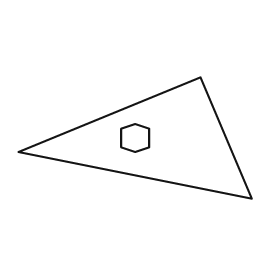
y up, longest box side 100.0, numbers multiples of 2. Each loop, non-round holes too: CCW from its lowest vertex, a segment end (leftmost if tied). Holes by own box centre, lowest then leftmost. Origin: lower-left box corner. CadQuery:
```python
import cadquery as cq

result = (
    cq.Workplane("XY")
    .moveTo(100.0, 0.0)
    .lineTo(78.0, 52.0)
    .lineTo(0.0, 20.0)
    .close()
    .moveTo(50.0, 20.0)
    .lineTo(56.0, 22.0)
    .lineTo(56.0, 30.0)
    .lineTo(50.0, 32.0)
    .lineTo(44.0, 30.0)
    .lineTo(44.0, 22.0)
    .close()
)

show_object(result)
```